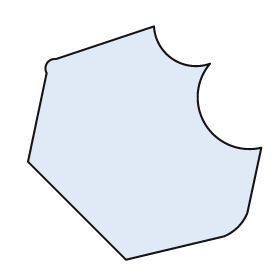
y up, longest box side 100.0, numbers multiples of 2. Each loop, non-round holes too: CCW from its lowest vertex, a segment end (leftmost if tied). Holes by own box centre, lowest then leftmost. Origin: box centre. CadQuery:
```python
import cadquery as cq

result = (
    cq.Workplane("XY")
    .moveTo(-8.0, -50.0)
    .lineTo(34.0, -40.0)
    .threePointArc((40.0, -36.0), (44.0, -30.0))
    .lineTo(50.0, -2.0)
    .threePointArc((26.0, 8.0), (28.0, 34.0))
    .threePointArc((12.0, 36.0), (4.0, 50.0))
    .lineTo(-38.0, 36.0)
    .threePointArc((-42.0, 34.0), (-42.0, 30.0))
    .lineTo(-50.0, -8.0)
    .close()
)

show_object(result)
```